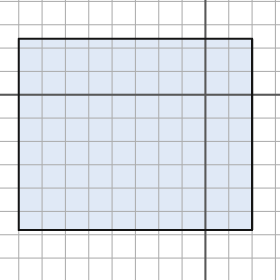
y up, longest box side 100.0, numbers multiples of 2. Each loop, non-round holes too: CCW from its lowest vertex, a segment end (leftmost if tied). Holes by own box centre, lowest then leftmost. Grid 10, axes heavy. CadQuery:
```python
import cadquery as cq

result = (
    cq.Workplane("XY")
    .moveTo(-80.0, -58.0)
    .lineTo(20.0, -58.0)
    .lineTo(20.0, 24.0)
    .lineTo(-80.0, 24.0)
    .close()
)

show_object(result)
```